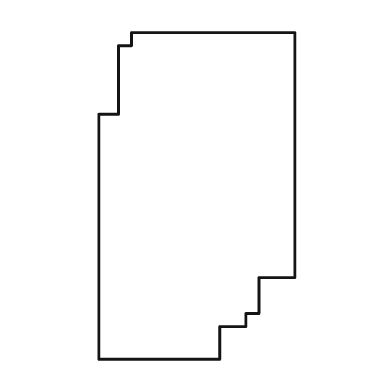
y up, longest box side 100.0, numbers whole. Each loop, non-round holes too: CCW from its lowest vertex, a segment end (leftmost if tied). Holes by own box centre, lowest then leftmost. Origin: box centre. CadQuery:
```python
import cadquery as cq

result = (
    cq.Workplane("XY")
    .moveTo(-30.0, -50.0)
    .lineTo(7.0, -50.0)
    .lineTo(7.0, -40.0)
    .lineTo(15.0, -40.0)
    .lineTo(15.0, -36.0)
    .lineTo(19.0, -36.0)
    .lineTo(19.0, -25.0)
    .lineTo(30.0, -25.0)
    .lineTo(30.0, 50.0)
    .lineTo(-20.0, 50.0)
    .lineTo(-20.0, 46.0)
    .lineTo(-24.0, 46.0)
    .lineTo(-24.0, 25.0)
    .lineTo(-30.0, 25.0)
    .close()
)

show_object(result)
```